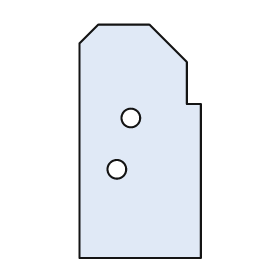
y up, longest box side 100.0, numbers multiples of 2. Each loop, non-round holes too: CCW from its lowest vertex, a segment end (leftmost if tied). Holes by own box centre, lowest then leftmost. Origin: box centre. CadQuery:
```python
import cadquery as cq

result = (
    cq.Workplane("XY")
    .moveTo(-26.0, -50.0)
    .lineTo(26.0, -50.0)
    .lineTo(26.0, 16.0)
    .lineTo(20.0, 16.0)
    .lineTo(20.0, 34.0)
    .lineTo(4.0, 50.0)
    .lineTo(-18.0, 50.0)
    .lineTo(-26.0, 42.0)
    .close()
    .moveTo(-10.0, -12.0)
    .circle(4.0)
    .moveTo(-4.0, 10.0)
    .circle(4.0)
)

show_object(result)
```